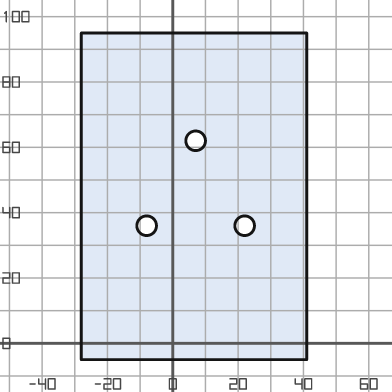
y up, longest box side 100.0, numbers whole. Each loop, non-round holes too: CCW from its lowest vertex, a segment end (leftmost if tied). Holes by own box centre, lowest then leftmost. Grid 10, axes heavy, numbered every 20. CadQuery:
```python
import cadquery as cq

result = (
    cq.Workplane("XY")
    .moveTo(-28.0, -5.0)
    .lineTo(41.0, -5.0)
    .lineTo(41.0, 95.0)
    .lineTo(-28.0, 95.0)
    .close()
    .moveTo(-8.0, 36.0)
    .circle(3.0)
    .moveTo(22.0, 36.0)
    .circle(3.0)
    .moveTo(7.0, 62.0)
    .circle(3.0)
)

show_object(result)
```